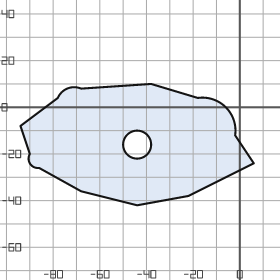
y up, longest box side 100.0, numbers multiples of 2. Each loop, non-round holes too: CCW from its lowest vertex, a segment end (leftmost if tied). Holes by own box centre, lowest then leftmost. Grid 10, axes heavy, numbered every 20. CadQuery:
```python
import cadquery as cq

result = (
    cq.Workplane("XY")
    .moveTo(-44.0, -42.0)
    .lineTo(-22.0, -38.0)
    .lineTo(6.0, -24.0)
    .lineTo(-2.0, -12.0)
    .threePointArc((-6.0, 0.0), (-18.0, 4.0))
    .lineTo(-38.0, 10.0)
    .lineTo(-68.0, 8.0)
    .threePointArc((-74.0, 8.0), (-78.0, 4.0))
    .lineTo(-94.0, -8.0)
    .lineTo(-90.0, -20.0)
    .threePointArc((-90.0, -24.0), (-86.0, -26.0))
    .lineTo(-68.0, -36.0)
    .close()
    .moveTo(-44.0, -16.0)
    .circle(6.0)
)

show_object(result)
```